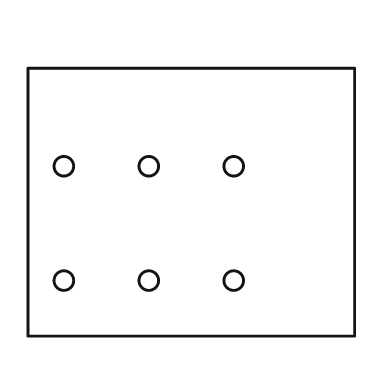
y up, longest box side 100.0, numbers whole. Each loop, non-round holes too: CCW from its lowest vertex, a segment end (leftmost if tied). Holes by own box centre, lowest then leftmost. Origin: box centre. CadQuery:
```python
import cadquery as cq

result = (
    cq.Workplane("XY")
    .moveTo(-50.0, -41.0)
    .lineTo(50.0, -41.0)
    .lineTo(50.0, 41.0)
    .lineTo(-50.0, 41.0)
    .close()
    .moveTo(-39.0, -24.0)
    .circle(3.0)
    .moveTo(-13.0, -24.0)
    .circle(3.0)
    .moveTo(13.0, -24.0)
    .circle(3.0)
    .moveTo(-39.0, 11.0)
    .circle(3.0)
    .moveTo(-13.0, 11.0)
    .circle(3.0)
    .moveTo(13.0, 11.0)
    .circle(3.0)
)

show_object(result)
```